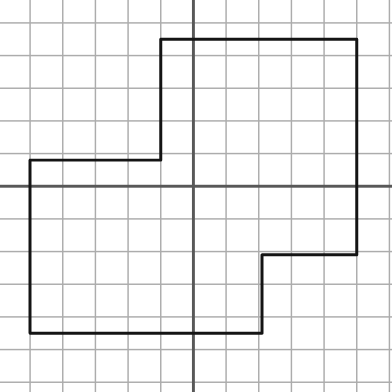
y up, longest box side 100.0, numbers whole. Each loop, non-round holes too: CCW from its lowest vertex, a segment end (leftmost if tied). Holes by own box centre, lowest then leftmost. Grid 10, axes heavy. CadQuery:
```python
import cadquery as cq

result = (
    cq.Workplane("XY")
    .moveTo(-50.0, -45.0)
    .lineTo(21.0, -45.0)
    .lineTo(21.0, -21.0)
    .lineTo(50.0, -21.0)
    .lineTo(50.0, 45.0)
    .lineTo(-10.0, 45.0)
    .lineTo(-10.0, 8.0)
    .lineTo(-50.0, 8.0)
    .close()
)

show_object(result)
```